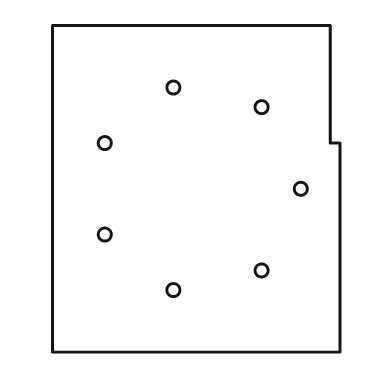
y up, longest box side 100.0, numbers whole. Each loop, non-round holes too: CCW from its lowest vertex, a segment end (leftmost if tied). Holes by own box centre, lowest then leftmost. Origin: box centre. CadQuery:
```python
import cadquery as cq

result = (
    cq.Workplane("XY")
    .moveTo(-44.0, -50.0)
    .lineTo(44.0, -50.0)
    .lineTo(44.0, 14.0)
    .lineTo(41.0, 14.0)
    .lineTo(41.0, 50.0)
    .lineTo(-44.0, 50.0)
    .close()
    .moveTo(-7.0, -31.0)
    .circle(2.0)
    .moveTo(20.0, -25.0)
    .circle(2.0)
    .moveTo(-28.0, -14.0)
    .circle(2.0)
    .moveTo(32.0, 0.0)
    .circle(2.0)
    .moveTo(-28.0, 14.0)
    .circle(2.0)
    .moveTo(20.0, 25.0)
    .circle(2.0)
    .moveTo(-7.0, 31.0)
    .circle(2.0)
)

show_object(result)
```